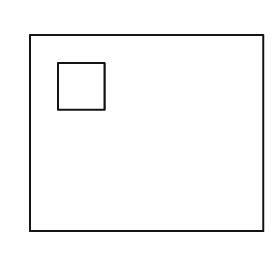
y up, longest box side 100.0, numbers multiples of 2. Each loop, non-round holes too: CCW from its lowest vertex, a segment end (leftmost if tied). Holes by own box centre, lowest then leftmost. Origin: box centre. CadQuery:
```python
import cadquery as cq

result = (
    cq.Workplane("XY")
    .moveTo(-50.0, -42.0)
    .lineTo(50.0, -42.0)
    .lineTo(50.0, 42.0)
    .lineTo(-50.0, 42.0)
    .close()
    .moveTo(-38.0, 10.0)
    .lineTo(-18.0, 10.0)
    .lineTo(-18.0, 30.0)
    .lineTo(-38.0, 30.0)
    .close()
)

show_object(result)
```